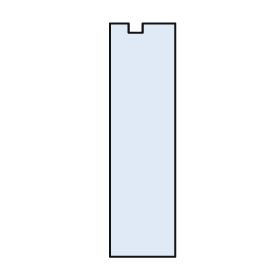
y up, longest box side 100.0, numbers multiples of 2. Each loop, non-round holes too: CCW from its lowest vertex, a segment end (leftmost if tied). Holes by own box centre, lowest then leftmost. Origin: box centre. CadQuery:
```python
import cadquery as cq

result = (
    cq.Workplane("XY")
    .moveTo(-14.0, -50.0)
    .lineTo(14.0, -50.0)
    .lineTo(14.0, 50.0)
    .lineTo(0.0, 50.0)
    .lineTo(0.0, 46.0)
    .lineTo(-6.0, 46.0)
    .lineTo(-6.0, 50.0)
    .lineTo(-14.0, 50.0)
    .close()
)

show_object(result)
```